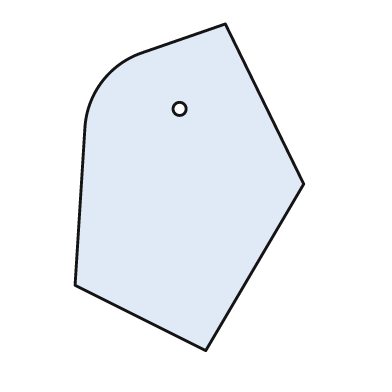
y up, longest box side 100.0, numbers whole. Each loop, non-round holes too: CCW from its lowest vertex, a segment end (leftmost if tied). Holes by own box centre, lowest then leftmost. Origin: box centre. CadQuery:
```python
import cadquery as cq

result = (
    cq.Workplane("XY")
    .moveTo(5.0, -50.0)
    .lineTo(35.0, 1.0)
    .lineTo(11.0, 50.0)
    .lineTo(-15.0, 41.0)
    .threePointArc((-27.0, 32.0), (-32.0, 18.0))
    .lineTo(-35.0, -30.0)
    .close()
    .moveTo(-3.0, 24.0)
    .circle(2.0)
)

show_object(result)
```